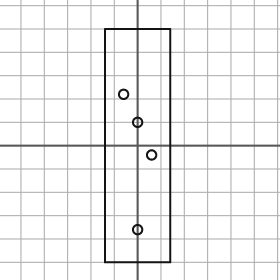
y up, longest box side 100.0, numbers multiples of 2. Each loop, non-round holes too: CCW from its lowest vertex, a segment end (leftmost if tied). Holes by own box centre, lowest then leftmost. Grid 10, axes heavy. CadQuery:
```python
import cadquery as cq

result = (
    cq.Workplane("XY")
    .moveTo(-14.0, -50.0)
    .lineTo(14.0, -50.0)
    .lineTo(14.0, 50.0)
    .lineTo(-14.0, 50.0)
    .close()
    .moveTo(0.0, -36.0)
    .circle(2.0)
    .moveTo(6.0, -4.0)
    .circle(2.0)
    .moveTo(0.0, 10.0)
    .circle(2.0)
    .moveTo(-6.0, 22.0)
    .circle(2.0)
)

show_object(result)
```